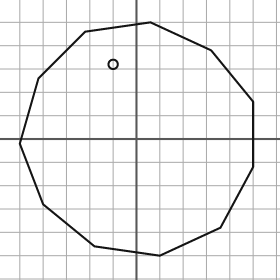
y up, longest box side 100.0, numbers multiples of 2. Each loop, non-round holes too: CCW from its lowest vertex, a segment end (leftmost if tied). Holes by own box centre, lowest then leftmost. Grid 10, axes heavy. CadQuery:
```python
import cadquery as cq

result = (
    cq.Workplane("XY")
    .moveTo(10.0, -50.0)
    .lineTo(36.0, -38.0)
    .lineTo(50.0, -12.0)
    .lineTo(50.0, 16.0)
    .lineTo(32.0, 38.0)
    .lineTo(6.0, 50.0)
    .lineTo(-22.0, 46.0)
    .lineTo(-42.0, 26.0)
    .lineTo(-50.0, -2.0)
    .lineTo(-40.0, -28.0)
    .lineTo(-18.0, -46.0)
    .close()
    .moveTo(-10.0, 32.0)
    .circle(2.0)
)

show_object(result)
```